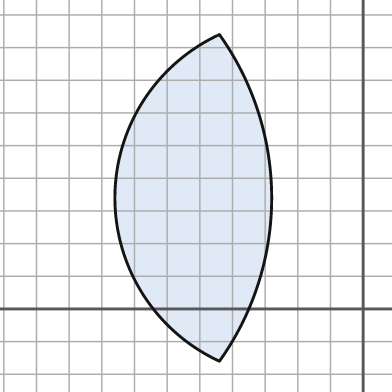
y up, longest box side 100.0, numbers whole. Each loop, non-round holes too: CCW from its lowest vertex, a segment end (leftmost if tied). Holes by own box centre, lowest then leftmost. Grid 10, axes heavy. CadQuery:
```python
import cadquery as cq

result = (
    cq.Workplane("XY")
    .moveTo(-44.0, -16.0)
    .threePointArc((-28.0, 34.0), (-44.0, 84.0))
    .threePointArc((-76.0, 34.0), (-44.0, -16.0))
    .close()
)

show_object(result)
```